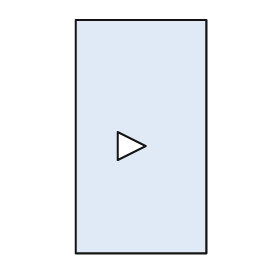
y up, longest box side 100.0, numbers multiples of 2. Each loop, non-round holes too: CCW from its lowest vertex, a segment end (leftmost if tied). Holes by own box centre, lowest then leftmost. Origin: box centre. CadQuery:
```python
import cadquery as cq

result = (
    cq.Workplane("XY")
    .moveTo(-28.0, -50.0)
    .lineTo(28.0, -50.0)
    .lineTo(28.0, 50.0)
    .lineTo(-28.0, 50.0)
    .close()
    .moveTo(-10.0, -10.0)
    .lineTo(2.0, -4.0)
    .lineTo(-10.0, 2.0)
    .close()
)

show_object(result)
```